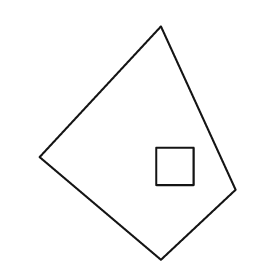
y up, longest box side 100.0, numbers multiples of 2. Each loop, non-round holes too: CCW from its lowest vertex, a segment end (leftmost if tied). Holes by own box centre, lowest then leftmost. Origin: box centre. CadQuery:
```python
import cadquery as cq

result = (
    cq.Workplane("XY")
    .moveTo(10.0, -50.0)
    .lineTo(42.0, -20.0)
    .lineTo(10.0, 50.0)
    .lineTo(-42.0, -6.0)
    .close()
    .moveTo(8.0, -18.0)
    .lineTo(24.0, -18.0)
    .lineTo(24.0, -2.0)
    .lineTo(8.0, -2.0)
    .close()
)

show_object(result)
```